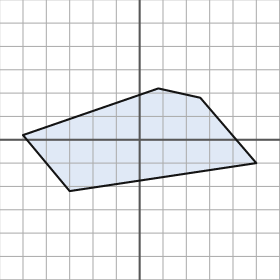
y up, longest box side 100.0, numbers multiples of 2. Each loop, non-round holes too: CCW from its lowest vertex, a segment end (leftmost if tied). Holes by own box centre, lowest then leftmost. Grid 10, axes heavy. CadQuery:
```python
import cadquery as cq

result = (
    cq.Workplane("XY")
    .moveTo(-30.0, -22.0)
    .lineTo(50.0, -10.0)
    .lineTo(26.0, 18.0)
    .lineTo(8.0, 22.0)
    .lineTo(-50.0, 2.0)
    .close()
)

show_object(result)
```